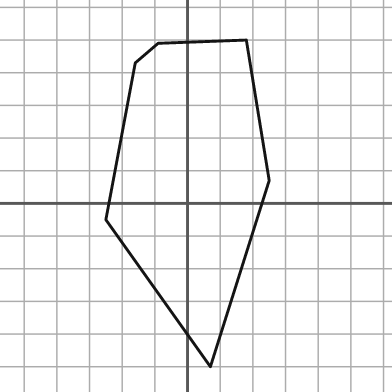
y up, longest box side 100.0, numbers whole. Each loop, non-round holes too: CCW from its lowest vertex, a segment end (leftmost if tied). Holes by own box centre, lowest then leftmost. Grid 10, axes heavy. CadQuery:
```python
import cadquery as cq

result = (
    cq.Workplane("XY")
    .moveTo(7.0, -50.0)
    .lineTo(25.0, 7.0)
    .lineTo(18.0, 50.0)
    .lineTo(-9.0, 49.0)
    .lineTo(-16.0, 43.0)
    .lineTo(-25.0, -5.0)
    .close()
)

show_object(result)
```